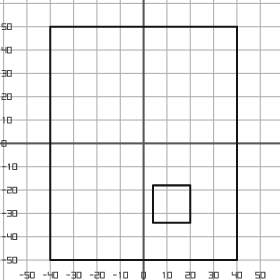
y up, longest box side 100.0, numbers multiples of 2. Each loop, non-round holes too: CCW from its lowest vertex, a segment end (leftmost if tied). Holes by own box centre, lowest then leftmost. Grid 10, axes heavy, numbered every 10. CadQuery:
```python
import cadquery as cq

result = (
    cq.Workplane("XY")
    .moveTo(-40.0, -50.0)
    .lineTo(40.0, -50.0)
    .lineTo(40.0, 50.0)
    .lineTo(-40.0, 50.0)
    .close()
    .moveTo(4.0, -34.0)
    .lineTo(20.0, -34.0)
    .lineTo(20.0, -18.0)
    .lineTo(4.0, -18.0)
    .close()
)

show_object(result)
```